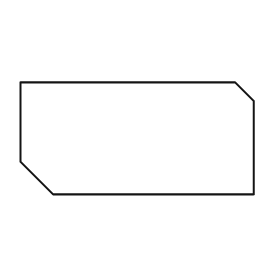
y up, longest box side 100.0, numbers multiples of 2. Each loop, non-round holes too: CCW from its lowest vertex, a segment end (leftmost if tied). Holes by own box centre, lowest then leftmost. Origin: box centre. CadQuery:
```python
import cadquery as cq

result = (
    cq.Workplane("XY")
    .moveTo(-36.0, -24.0)
    .lineTo(50.0, -24.0)
    .lineTo(50.0, 16.0)
    .lineTo(42.0, 24.0)
    .lineTo(-50.0, 24.0)
    .lineTo(-50.0, -10.0)
    .close()
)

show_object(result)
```